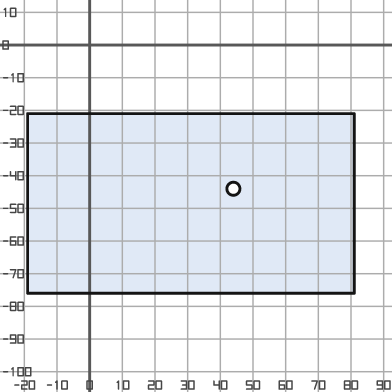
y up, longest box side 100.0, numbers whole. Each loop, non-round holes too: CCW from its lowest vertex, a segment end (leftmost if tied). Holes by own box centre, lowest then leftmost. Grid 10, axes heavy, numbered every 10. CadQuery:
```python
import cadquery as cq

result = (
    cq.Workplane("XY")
    .moveTo(-19.0, -76.0)
    .lineTo(81.0, -76.0)
    .lineTo(81.0, -21.0)
    .lineTo(-19.0, -21.0)
    .close()
    .moveTo(44.0, -44.0)
    .circle(2.0)
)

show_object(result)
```